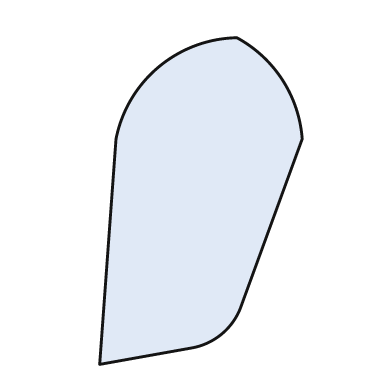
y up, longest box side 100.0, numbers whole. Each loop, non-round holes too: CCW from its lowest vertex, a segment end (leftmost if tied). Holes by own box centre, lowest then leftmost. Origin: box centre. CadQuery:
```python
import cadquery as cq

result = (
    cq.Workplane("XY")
    .moveTo(-31.0, -50.0)
    .lineTo(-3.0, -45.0)
    .threePointArc((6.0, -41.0), (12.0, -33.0))
    .lineTo(31.0, 19.0)
    .threePointArc((25.0, 37.0), (11.0, 50.0))
    .threePointArc((-13.0, 41.0), (-26.0, 19.0))
    .close()
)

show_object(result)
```